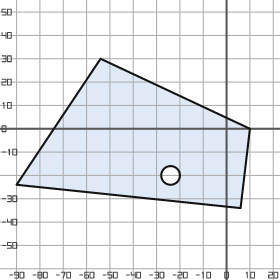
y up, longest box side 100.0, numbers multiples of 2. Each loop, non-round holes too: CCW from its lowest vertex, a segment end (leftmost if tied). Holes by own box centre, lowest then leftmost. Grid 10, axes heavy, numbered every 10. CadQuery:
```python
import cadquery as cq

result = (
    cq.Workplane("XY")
    .moveTo(6.0, -34.0)
    .lineTo(10.0, 0.0)
    .lineTo(-54.0, 30.0)
    .lineTo(-90.0, -24.0)
    .close()
    .moveTo(-24.0, -20.0)
    .circle(4.0)
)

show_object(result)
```